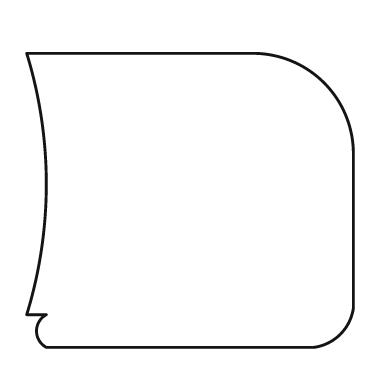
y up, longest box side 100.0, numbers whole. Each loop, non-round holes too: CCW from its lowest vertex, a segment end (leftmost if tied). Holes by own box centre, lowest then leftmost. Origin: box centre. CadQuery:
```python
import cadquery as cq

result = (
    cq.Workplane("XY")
    .moveTo(-44.0, -45.0)
    .lineTo(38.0, -45.0)
    .threePointArc((46.0, -41.0), (50.0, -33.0))
    .lineTo(50.0, 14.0)
    .threePointArc((41.0, 36.0), (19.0, 45.0))
    .lineTo(-50.0, 45.0)
    .threePointArc((-44.0, 5.0), (-50.0, -35.0))
    .lineTo(-44.0, -35.0)
    .threePointArc((-47.0, -40.0), (-44.0, -45.0))
    .close()
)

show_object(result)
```